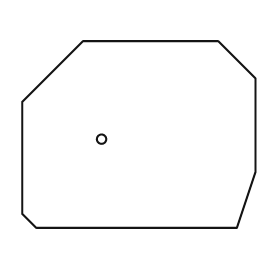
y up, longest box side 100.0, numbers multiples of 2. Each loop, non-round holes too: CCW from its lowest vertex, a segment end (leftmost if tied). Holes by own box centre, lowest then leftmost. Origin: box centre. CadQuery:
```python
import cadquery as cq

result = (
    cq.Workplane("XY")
    .moveTo(-44.0, -40.0)
    .lineTo(42.0, -40.0)
    .lineTo(50.0, -16.0)
    .lineTo(50.0, 24.0)
    .lineTo(34.0, 40.0)
    .lineTo(-24.0, 40.0)
    .lineTo(-50.0, 14.0)
    .lineTo(-50.0, -34.0)
    .close()
    .moveTo(-16.0, -2.0)
    .circle(2.0)
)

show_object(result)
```